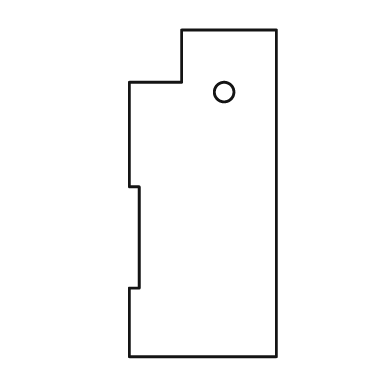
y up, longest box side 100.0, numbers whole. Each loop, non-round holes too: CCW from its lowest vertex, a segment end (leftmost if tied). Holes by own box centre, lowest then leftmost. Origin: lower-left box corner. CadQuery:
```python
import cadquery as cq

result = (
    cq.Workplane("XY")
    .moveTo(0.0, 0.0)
    .lineTo(45.0, 0.0)
    .lineTo(45.0, 100.0)
    .lineTo(16.0, 100.0)
    .lineTo(16.0, 84.0)
    .lineTo(0.0, 84.0)
    .lineTo(0.0, 52.0)
    .lineTo(3.0, 52.0)
    .lineTo(3.0, 21.0)
    .lineTo(0.0, 21.0)
    .close()
    .moveTo(29.0, 81.0)
    .circle(3.0)
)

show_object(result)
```